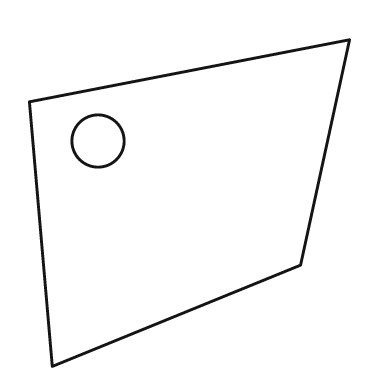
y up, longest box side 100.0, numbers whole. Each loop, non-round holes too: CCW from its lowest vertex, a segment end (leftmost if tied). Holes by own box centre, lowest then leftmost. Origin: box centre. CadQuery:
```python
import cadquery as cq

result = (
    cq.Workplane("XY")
    .moveTo(-42.0, -50.0)
    .lineTo(34.0, -19.0)
    .lineTo(49.0, 50.0)
    .lineTo(-49.0, 31.0)
    .close()
    .moveTo(-28.0, 19.0)
    .circle(8.0)
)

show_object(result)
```